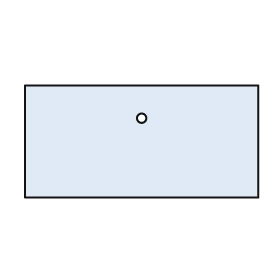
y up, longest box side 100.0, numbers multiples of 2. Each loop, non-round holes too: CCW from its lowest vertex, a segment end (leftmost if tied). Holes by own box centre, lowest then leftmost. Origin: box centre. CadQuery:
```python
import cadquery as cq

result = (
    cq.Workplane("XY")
    .moveTo(-50.0, -24.0)
    .lineTo(50.0, -24.0)
    .lineTo(50.0, 24.0)
    .lineTo(-50.0, 24.0)
    .close()
    .moveTo(0.0, 10.0)
    .circle(2.0)
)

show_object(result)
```